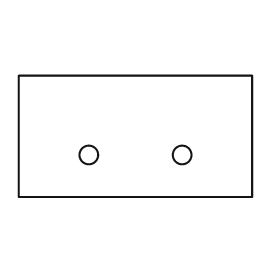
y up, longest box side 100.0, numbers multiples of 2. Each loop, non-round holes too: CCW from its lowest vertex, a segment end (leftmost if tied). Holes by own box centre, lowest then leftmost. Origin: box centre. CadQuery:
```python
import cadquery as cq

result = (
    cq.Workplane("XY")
    .moveTo(-50.0, -26.0)
    .lineTo(50.0, -26.0)
    .lineTo(50.0, 26.0)
    .lineTo(-50.0, 26.0)
    .close()
    .moveTo(-20.0, -8.0)
    .circle(4.0)
    .moveTo(20.0, -8.0)
    .circle(4.0)
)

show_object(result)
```